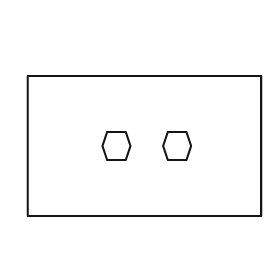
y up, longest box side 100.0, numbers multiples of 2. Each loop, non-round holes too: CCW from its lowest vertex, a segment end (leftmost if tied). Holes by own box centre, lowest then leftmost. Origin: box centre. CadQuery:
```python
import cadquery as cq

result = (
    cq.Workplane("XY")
    .moveTo(-50.0, -30.0)
    .lineTo(50.0, -30.0)
    .lineTo(50.0, 30.0)
    .lineTo(-50.0, 30.0)
    .close()
    .moveTo(-16.0, -6.0)
    .lineTo(-8.0, -6.0)
    .lineTo(-6.0, 0.0)
    .lineTo(-8.0, 6.0)
    .lineTo(-16.0, 6.0)
    .lineTo(-18.0, 0.0)
    .close()
    .moveTo(10.0, -6.0)
    .lineTo(18.0, -6.0)
    .lineTo(20.0, 0.0)
    .lineTo(18.0, 6.0)
    .lineTo(10.0, 6.0)
    .lineTo(8.0, 0.0)
    .close()
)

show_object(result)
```